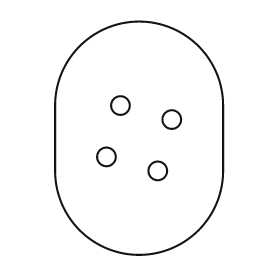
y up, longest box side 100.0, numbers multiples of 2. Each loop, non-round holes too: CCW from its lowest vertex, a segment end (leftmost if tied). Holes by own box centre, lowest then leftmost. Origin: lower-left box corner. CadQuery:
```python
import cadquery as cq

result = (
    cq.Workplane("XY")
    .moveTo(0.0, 36.0)
    .threePointArc((36.0, 0.0), (72.0, 36.0))
    .lineTo(72.0, 64.0)
    .threePointArc((36.0, 100.0), (0.0, 64.0))
    .close()
    .moveTo(44.0, 36.0)
    .circle(4.0)
    .moveTo(22.0, 42.0)
    .circle(4.0)
    .moveTo(50.0, 58.0)
    .circle(4.0)
    .moveTo(28.0, 64.0)
    .circle(4.0)
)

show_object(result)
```